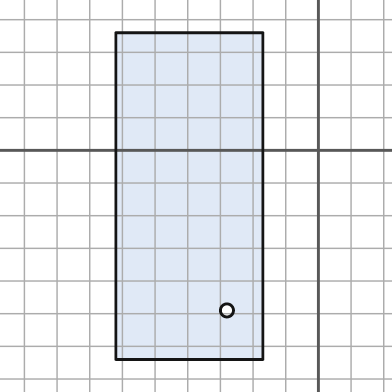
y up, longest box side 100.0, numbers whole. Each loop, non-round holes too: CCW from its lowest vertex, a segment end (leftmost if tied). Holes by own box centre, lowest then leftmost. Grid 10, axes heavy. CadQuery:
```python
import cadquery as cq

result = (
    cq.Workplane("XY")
    .moveTo(-62.0, -64.0)
    .lineTo(-17.0, -64.0)
    .lineTo(-17.0, 36.0)
    .lineTo(-62.0, 36.0)
    .close()
    .moveTo(-28.0, -49.0)
    .circle(2.0)
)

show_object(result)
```